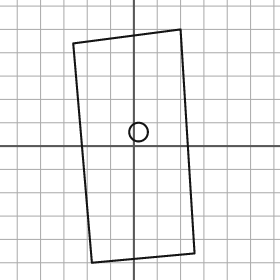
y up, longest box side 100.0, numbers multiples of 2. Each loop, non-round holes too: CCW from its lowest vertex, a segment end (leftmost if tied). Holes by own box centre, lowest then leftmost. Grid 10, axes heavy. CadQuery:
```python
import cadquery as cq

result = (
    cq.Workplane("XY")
    .moveTo(-18.0, -50.0)
    .lineTo(26.0, -46.0)
    .lineTo(20.0, 50.0)
    .lineTo(-26.0, 44.0)
    .close()
    .moveTo(2.0, 6.0)
    .circle(4.0)
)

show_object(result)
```